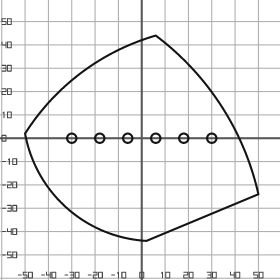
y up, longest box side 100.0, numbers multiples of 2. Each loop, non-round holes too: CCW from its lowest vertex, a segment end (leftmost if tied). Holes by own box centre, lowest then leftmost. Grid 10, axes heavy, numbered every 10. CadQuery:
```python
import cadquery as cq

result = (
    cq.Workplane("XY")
    .moveTo(2.0, -44.0)
    .lineTo(50.0, -24.0)
    .threePointArc((34.0, 14.0), (6.0, 44.0))
    .threePointArc((-26.0, 28.0), (-50.0, 2.0))
    .threePointArc((-32.0, -30.0), (2.0, -44.0))
    .close()
    .moveTo(-30.0, 0.0)
    .circle(2.0)
    .moveTo(-18.0, 0.0)
    .circle(2.0)
    .moveTo(-6.0, 0.0)
    .circle(2.0)
    .moveTo(6.0, 0.0)
    .circle(2.0)
    .moveTo(18.0, 0.0)
    .circle(2.0)
    .moveTo(30.0, 0.0)
    .circle(2.0)
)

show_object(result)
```